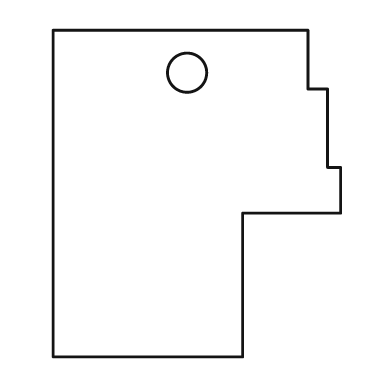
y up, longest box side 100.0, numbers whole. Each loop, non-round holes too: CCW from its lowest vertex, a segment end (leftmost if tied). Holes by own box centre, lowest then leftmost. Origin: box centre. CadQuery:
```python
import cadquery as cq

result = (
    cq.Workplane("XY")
    .moveTo(-44.0, -50.0)
    .lineTo(14.0, -50.0)
    .lineTo(14.0, -6.0)
    .lineTo(44.0, -6.0)
    .lineTo(44.0, 8.0)
    .lineTo(40.0, 8.0)
    .lineTo(40.0, 32.0)
    .lineTo(34.0, 32.0)
    .lineTo(34.0, 50.0)
    .lineTo(-44.0, 50.0)
    .close()
    .moveTo(-3.0, 37.0)
    .circle(6.0)
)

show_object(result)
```